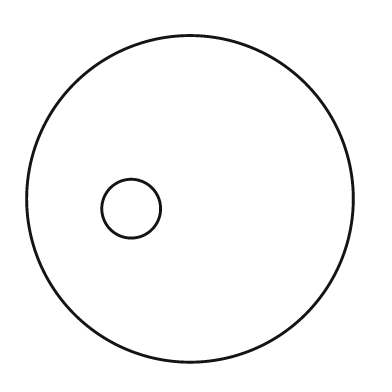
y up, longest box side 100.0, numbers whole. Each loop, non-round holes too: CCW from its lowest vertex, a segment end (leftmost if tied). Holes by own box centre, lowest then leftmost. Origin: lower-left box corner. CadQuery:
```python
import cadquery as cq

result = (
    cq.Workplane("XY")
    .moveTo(50.0, 50.0)
    .circle(50.0)
    .moveTo(32.0, 47.0)
    .circle(9.0)
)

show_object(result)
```